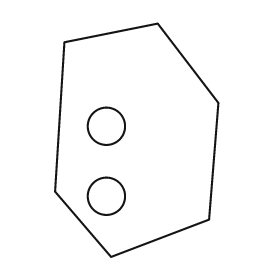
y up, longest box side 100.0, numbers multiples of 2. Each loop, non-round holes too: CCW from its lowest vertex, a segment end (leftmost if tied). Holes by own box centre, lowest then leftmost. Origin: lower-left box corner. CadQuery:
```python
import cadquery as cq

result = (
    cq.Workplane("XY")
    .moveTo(24.0, 0.0)
    .lineTo(66.0, 16.0)
    .lineTo(70.0, 66.0)
    .lineTo(44.0, 100.0)
    .lineTo(4.0, 92.0)
    .lineTo(0.0, 28.0)
    .close()
    .moveTo(22.0, 26.0)
    .circle(8.0)
    .moveTo(22.0, 56.0)
    .circle(8.0)
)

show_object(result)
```